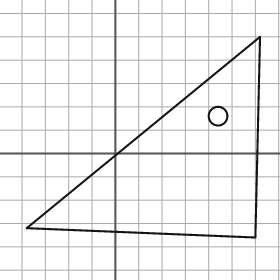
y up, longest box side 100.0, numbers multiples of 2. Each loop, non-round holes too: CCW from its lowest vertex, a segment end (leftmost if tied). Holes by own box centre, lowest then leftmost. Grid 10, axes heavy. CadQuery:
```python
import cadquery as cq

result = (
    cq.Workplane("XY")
    .moveTo(60.0, -36.0)
    .lineTo(62.0, 50.0)
    .lineTo(-38.0, -32.0)
    .close()
    .moveTo(44.0, 16.0)
    .circle(4.0)
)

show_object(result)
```